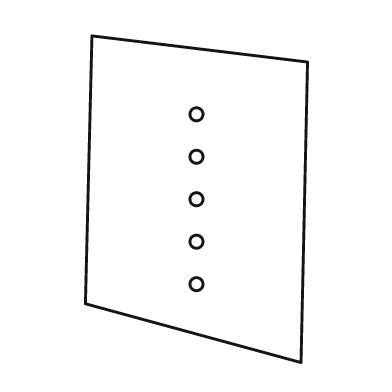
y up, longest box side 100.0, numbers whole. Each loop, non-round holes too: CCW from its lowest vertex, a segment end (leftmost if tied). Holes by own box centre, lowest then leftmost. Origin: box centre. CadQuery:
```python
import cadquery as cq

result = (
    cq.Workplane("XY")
    .moveTo(32.0, -50.0)
    .lineTo(34.0, 42.0)
    .lineTo(-32.0, 50.0)
    .lineTo(-34.0, -32.0)
    .close()
    .moveTo(0.0, -26.0)
    .circle(2.0)
    .moveTo(0.0, -13.0)
    .circle(2.0)
    .moveTo(0.0, 0.0)
    .circle(2.0)
    .moveTo(0.0, 13.0)
    .circle(2.0)
    .moveTo(0.0, 26.0)
    .circle(2.0)
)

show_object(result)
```